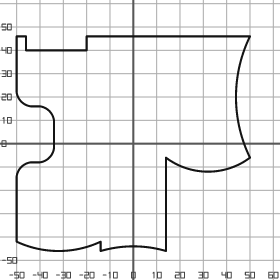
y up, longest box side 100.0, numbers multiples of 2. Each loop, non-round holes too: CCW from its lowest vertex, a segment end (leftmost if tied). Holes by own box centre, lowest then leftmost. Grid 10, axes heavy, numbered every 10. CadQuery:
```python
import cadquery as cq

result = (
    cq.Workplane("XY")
    .moveTo(-14.0, -46.0)
    .threePointArc((0.0, -44.0), (14.0, -46.0))
    .lineTo(14.0, -6.0)
    .threePointArc((32.0, -12.0), (50.0, -6.0))
    .threePointArc((44.0, 20.0), (50.0, 46.0))
    .lineTo(-20.0, 46.0)
    .lineTo(-20.0, 40.0)
    .lineTo(-46.0, 40.0)
    .lineTo(-46.0, 46.0)
    .lineTo(-50.0, 46.0)
    .lineTo(-50.0, 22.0)
    .threePointArc((-48.0, 18.0), (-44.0, 16.0))
    .lineTo(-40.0, 16.0)
    .threePointArc((-36.0, 14.0), (-34.0, 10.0))
    .lineTo(-34.0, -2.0)
    .threePointArc((-36.0, -6.0), (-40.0, -8.0))
    .lineTo(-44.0, -8.0)
    .threePointArc((-48.0, -10.0), (-50.0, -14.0))
    .lineTo(-50.0, -42.0)
    .threePointArc((-32.0, -46.0), (-14.0, -42.0))
    .close()
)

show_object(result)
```